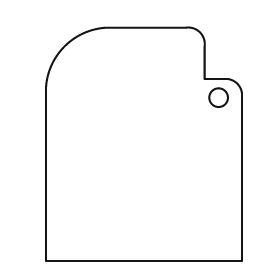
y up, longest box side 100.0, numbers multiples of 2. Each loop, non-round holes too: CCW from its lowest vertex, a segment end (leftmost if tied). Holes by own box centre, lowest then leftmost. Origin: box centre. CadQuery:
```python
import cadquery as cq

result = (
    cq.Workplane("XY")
    .moveTo(-42.0, -50.0)
    .lineTo(42.0, -50.0)
    .lineTo(42.0, 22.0)
    .threePointArc((40.0, 26.0), (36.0, 28.0))
    .lineTo(26.0, 28.0)
    .lineTo(26.0, 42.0)
    .threePointArc((24.0, 48.0), (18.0, 50.0))
    .lineTo(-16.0, 50.0)
    .threePointArc((-34.0, 42.0), (-42.0, 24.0))
    .close()
    .moveTo(32.0, 20.0)
    .circle(4.0)
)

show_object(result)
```